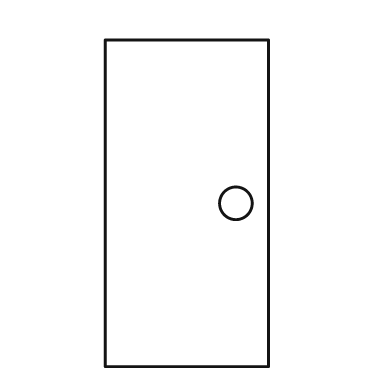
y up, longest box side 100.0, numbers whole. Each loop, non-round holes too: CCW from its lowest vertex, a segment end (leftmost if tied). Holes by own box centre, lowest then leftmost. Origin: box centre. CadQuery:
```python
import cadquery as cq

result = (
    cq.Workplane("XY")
    .moveTo(-25.0, -50.0)
    .lineTo(25.0, -50.0)
    .lineTo(25.0, 50.0)
    .lineTo(-25.0, 50.0)
    .close()
    .moveTo(15.0, 0.0)
    .circle(5.0)
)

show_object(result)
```